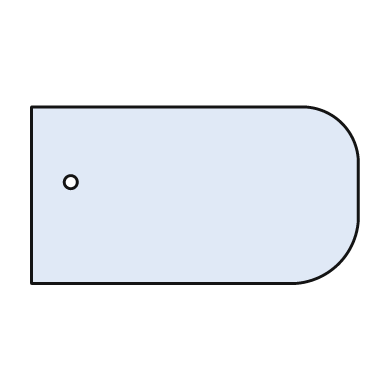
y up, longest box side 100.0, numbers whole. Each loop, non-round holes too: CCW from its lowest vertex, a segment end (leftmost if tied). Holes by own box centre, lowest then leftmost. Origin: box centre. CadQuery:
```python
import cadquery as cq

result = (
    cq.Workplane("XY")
    .moveTo(-50.0, -27.0)
    .lineTo(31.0, -27.0)
    .threePointArc((44.0, -21.0), (50.0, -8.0))
    .lineTo(50.0, 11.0)
    .threePointArc((45.0, 22.0), (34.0, 27.0))
    .lineTo(-50.0, 27.0)
    .close()
    .moveTo(-38.0, 4.0)
    .circle(2.0)
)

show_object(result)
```